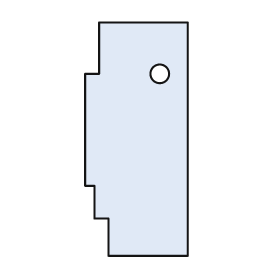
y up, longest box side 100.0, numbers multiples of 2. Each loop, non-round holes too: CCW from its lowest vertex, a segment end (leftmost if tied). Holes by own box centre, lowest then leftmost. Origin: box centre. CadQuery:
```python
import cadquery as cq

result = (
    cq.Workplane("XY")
    .moveTo(-12.0, -50.0)
    .lineTo(22.0, -50.0)
    .lineTo(22.0, 50.0)
    .lineTo(-16.0, 50.0)
    .lineTo(-16.0, 28.0)
    .lineTo(-22.0, 28.0)
    .lineTo(-22.0, -20.0)
    .lineTo(-18.0, -20.0)
    .lineTo(-18.0, -34.0)
    .lineTo(-12.0, -34.0)
    .close()
    .moveTo(10.0, 28.0)
    .circle(4.0)
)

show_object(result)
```